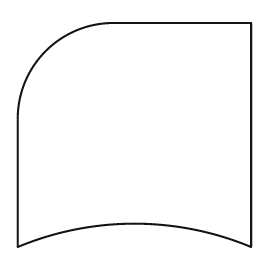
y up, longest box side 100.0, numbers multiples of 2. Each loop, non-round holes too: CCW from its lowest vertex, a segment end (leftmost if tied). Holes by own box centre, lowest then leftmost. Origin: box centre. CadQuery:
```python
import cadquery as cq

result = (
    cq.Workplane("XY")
    .moveTo(-50.0, -48.0)
    .threePointArc((0.0, -38.0), (50.0, -48.0))
    .lineTo(50.0, 48.0)
    .lineTo(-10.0, 48.0)
    .threePointArc((-38.0, 36.0), (-50.0, 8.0))
    .close()
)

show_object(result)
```